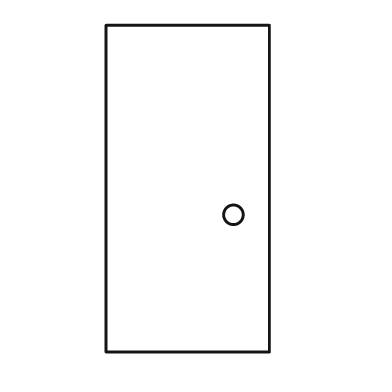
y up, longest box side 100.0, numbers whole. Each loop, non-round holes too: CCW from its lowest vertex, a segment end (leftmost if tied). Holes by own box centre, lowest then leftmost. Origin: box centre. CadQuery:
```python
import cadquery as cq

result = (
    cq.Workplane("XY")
    .moveTo(-25.0, -50.0)
    .lineTo(25.0, -50.0)
    .lineTo(25.0, 50.0)
    .lineTo(-25.0, 50.0)
    .close()
    .moveTo(14.0, -8.0)
    .circle(3.0)
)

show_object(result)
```